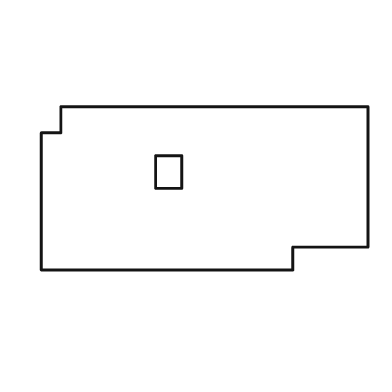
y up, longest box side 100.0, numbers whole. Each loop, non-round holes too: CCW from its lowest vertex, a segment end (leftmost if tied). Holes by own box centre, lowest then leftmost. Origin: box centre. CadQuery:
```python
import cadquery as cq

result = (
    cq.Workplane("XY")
    .moveTo(-50.0, -25.0)
    .lineTo(27.0, -25.0)
    .lineTo(27.0, -18.0)
    .lineTo(50.0, -18.0)
    .lineTo(50.0, 25.0)
    .lineTo(-44.0, 25.0)
    .lineTo(-44.0, 17.0)
    .lineTo(-50.0, 17.0)
    .close()
    .moveTo(-15.0, 0.0)
    .lineTo(-7.0, 0.0)
    .lineTo(-7.0, 10.0)
    .lineTo(-15.0, 10.0)
    .close()
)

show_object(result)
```